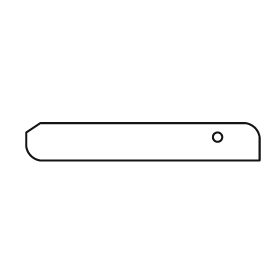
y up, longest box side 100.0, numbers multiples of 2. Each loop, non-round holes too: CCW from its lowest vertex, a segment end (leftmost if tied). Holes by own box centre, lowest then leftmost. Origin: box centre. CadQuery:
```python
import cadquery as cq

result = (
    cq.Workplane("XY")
    .moveTo(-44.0, -8.0)
    .lineTo(50.0, -8.0)
    .lineTo(50.0, 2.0)
    .threePointArc((48.0, 6.0), (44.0, 8.0))
    .lineTo(-44.0, 8.0)
    .lineTo(-50.0, 4.0)
    .lineTo(-50.0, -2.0)
    .threePointArc((-48.0, -6.0), (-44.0, -8.0))
    .close()
    .moveTo(32.0, 2.0)
    .circle(2.0)
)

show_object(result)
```